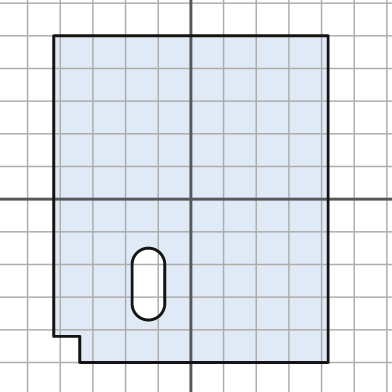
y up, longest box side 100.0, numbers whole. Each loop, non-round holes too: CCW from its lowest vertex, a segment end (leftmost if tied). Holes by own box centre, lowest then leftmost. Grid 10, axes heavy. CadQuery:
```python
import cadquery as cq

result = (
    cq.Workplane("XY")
    .moveTo(-34.0, -50.0)
    .lineTo(42.0, -50.0)
    .lineTo(42.0, 50.0)
    .lineTo(-42.0, 50.0)
    .lineTo(-42.0, -42.0)
    .lineTo(-34.0, -42.0)
    .close()
    .moveTo(-18.0, -32.0)
    .threePointArc((-13.0, -37.0), (-8.0, -32.0))
    .lineTo(-8.0, -20.0)
    .threePointArc((-13.0, -15.0), (-18.0, -20.0))
    .close()
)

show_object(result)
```